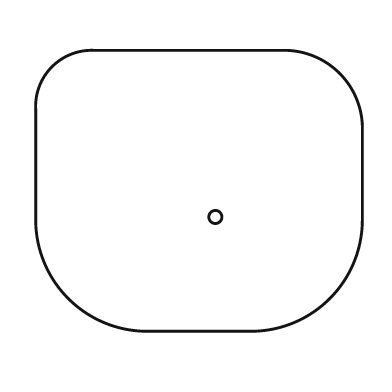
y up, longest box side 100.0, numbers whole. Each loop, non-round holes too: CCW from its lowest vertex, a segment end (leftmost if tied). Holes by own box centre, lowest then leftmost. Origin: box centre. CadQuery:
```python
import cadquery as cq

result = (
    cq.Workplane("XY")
    .moveTo(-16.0, -43.0)
    .lineTo(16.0, -43.0)
    .threePointArc((40.0, -33.0), (50.0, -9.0))
    .lineTo(50.0, 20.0)
    .threePointArc((43.0, 36.0), (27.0, 43.0))
    .lineTo(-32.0, 43.0)
    .threePointArc((-45.0, 38.0), (-50.0, 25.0))
    .lineTo(-50.0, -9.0)
    .threePointArc((-40.0, -33.0), (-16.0, -43.0))
    .close()
    .moveTo(5.0, -8.0)
    .circle(2.0)
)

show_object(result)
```